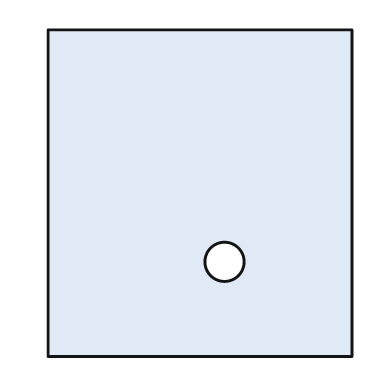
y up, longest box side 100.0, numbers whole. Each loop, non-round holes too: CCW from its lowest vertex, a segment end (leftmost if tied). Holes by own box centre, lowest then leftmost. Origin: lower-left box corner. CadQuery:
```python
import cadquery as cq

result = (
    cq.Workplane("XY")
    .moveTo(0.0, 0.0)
    .lineTo(93.0, 0.0)
    .lineTo(93.0, 100.0)
    .lineTo(0.0, 100.0)
    .close()
    .moveTo(54.0, 29.0)
    .circle(6.0)
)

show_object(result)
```